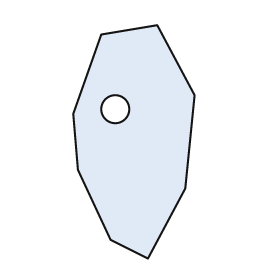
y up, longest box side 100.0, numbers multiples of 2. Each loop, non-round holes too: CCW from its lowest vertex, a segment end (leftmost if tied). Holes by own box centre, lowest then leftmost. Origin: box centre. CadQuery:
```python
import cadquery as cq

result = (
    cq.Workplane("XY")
    .moveTo(6.0, -50.0)
    .lineTo(22.0, -20.0)
    .lineTo(26.0, 20.0)
    .lineTo(10.0, 50.0)
    .lineTo(-14.0, 46.0)
    .lineTo(-26.0, 12.0)
    .lineTo(-24.0, -12.0)
    .lineTo(-10.0, -42.0)
    .close()
    .moveTo(-8.0, 14.0)
    .circle(6.0)
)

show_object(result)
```